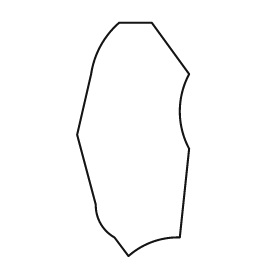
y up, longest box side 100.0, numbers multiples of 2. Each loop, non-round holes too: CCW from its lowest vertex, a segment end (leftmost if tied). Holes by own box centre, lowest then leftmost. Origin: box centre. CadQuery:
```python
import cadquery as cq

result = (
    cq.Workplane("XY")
    .moveTo(-2.0, -50.0)
    .threePointArc((8.0, -44.0), (20.0, -42.0))
    .lineTo(24.0, -4.0)
    .threePointArc((20.0, 12.0), (24.0, 28.0))
    .lineTo(8.0, 50.0)
    .lineTo(-6.0, 50.0)
    .threePointArc((-14.0, 40.0), (-18.0, 28.0))
    .lineTo(-24.0, 2.0)
    .lineTo(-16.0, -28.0)
    .threePointArc((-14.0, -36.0), (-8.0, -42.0))
    .close()
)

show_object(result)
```